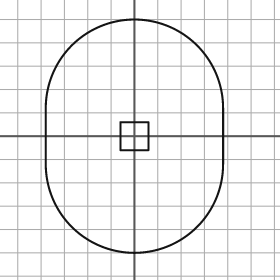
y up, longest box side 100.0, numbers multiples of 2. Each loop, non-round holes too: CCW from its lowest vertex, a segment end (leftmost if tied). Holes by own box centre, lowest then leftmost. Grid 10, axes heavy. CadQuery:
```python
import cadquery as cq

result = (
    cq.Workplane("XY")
    .moveTo(-38.0, -12.0)
    .threePointArc((0.0, -50.0), (38.0, -12.0))
    .lineTo(38.0, 12.0)
    .threePointArc((0.0, 50.0), (-38.0, 12.0))
    .close()
    .moveTo(-6.0, -6.0)
    .lineTo(6.0, -6.0)
    .lineTo(6.0, 6.0)
    .lineTo(-6.0, 6.0)
    .close()
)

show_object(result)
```